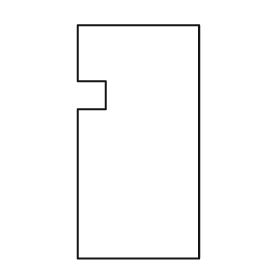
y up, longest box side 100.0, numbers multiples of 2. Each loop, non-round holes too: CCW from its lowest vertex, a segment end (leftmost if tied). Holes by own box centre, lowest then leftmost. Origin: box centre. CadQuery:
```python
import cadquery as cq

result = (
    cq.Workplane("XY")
    .moveTo(-26.0, -50.0)
    .lineTo(26.0, -50.0)
    .lineTo(26.0, 50.0)
    .lineTo(-26.0, 50.0)
    .lineTo(-26.0, 26.0)
    .lineTo(-14.0, 26.0)
    .lineTo(-14.0, 14.0)
    .lineTo(-26.0, 14.0)
    .close()
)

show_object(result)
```